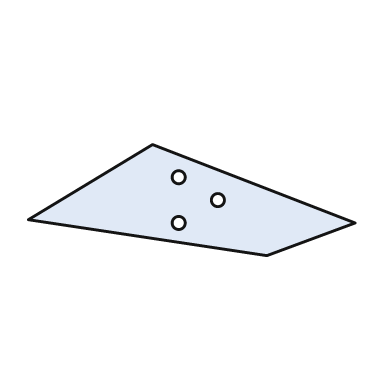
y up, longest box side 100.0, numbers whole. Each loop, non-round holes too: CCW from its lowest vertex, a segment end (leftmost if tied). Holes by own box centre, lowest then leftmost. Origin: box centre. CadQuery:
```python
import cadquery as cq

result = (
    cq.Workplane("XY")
    .moveTo(23.0, -17.0)
    .lineTo(50.0, -7.0)
    .lineTo(-12.0, 17.0)
    .lineTo(-50.0, -6.0)
    .close()
    .moveTo(-4.0, -7.0)
    .circle(2.0)
    .moveTo(8.0, 0.0)
    .circle(2.0)
    .moveTo(-4.0, 7.0)
    .circle(2.0)
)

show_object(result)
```